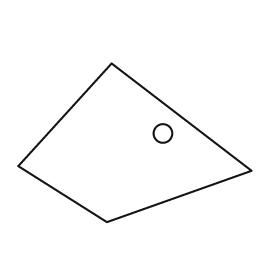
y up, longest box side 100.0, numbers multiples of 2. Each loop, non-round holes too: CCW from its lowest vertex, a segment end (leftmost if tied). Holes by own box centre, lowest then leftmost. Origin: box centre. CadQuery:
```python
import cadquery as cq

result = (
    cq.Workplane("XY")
    .moveTo(-12.0, -34.0)
    .lineTo(50.0, -12.0)
    .lineTo(-10.0, 34.0)
    .lineTo(-50.0, -10.0)
    .close()
    .moveTo(12.0, 4.0)
    .circle(4.0)
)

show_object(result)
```